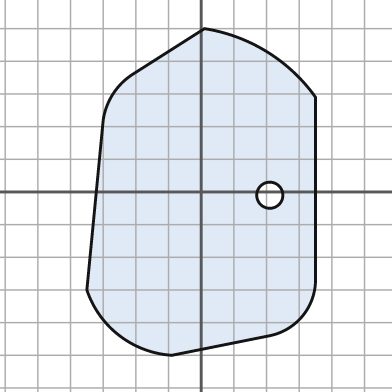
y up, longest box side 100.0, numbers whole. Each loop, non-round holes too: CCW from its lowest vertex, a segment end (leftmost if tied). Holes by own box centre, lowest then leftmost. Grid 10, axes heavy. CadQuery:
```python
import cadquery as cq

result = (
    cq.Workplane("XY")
    .moveTo(-9.0, -50.0)
    .lineTo(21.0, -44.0)
    .threePointArc((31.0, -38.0), (35.0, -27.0))
    .lineTo(35.0, 29.0)
    .threePointArc((20.0, 43.0), (1.0, 50.0))
    .lineTo(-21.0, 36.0)
    .threePointArc((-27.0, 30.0), (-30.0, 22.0))
    .lineTo(-35.0, -30.0)
    .threePointArc((-25.0, -44.0), (-9.0, -50.0))
    .close()
    .moveTo(21.0, -1.0)
    .circle(4.0)
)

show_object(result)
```